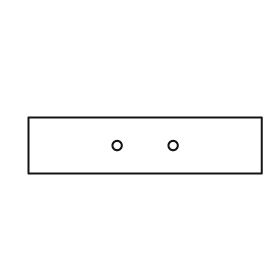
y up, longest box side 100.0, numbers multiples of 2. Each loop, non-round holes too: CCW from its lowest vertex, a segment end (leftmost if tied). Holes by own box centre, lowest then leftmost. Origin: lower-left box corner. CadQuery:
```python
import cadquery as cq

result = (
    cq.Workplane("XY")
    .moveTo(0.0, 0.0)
    .lineTo(100.0, 0.0)
    .lineTo(100.0, 24.0)
    .lineTo(0.0, 24.0)
    .close()
    .moveTo(38.0, 12.0)
    .circle(2.0)
    .moveTo(62.0, 12.0)
    .circle(2.0)
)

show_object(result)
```